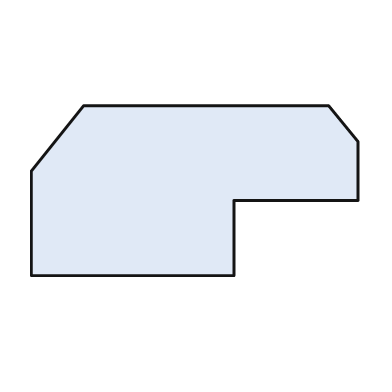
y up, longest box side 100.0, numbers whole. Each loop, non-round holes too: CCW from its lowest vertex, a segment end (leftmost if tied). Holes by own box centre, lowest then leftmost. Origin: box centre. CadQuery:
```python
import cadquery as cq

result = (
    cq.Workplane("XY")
    .moveTo(-50.0, -26.0)
    .lineTo(12.0, -26.0)
    .lineTo(12.0, -3.0)
    .lineTo(50.0, -3.0)
    .lineTo(50.0, 15.0)
    .lineTo(41.0, 26.0)
    .lineTo(-34.0, 26.0)
    .lineTo(-50.0, 6.0)
    .close()
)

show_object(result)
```